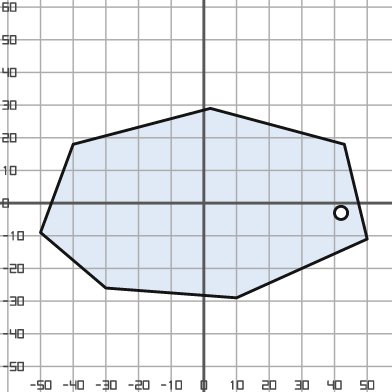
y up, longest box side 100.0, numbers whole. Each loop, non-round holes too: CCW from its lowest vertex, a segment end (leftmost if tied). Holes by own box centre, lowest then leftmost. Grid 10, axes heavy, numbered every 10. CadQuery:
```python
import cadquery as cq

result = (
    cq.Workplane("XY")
    .moveTo(10.0, -29.0)
    .lineTo(50.0, -11.0)
    .lineTo(43.0, 18.0)
    .lineTo(2.0, 29.0)
    .lineTo(-40.0, 18.0)
    .lineTo(-50.0, -9.0)
    .lineTo(-30.0, -26.0)
    .close()
    .moveTo(42.0, -3.0)
    .circle(2.0)
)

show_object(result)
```